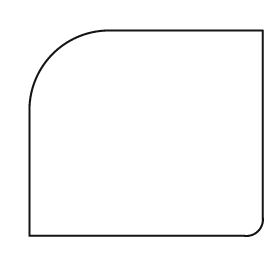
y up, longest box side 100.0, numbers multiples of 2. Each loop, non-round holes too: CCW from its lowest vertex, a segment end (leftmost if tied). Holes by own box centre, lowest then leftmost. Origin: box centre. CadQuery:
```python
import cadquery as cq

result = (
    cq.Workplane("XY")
    .moveTo(-50.0, -44.0)
    .lineTo(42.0, -44.0)
    .threePointArc((48.0, -42.0), (50.0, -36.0))
    .lineTo(50.0, 44.0)
    .lineTo(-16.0, 44.0)
    .threePointArc((-40.0, 34.0), (-50.0, 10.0))
    .close()
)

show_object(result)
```